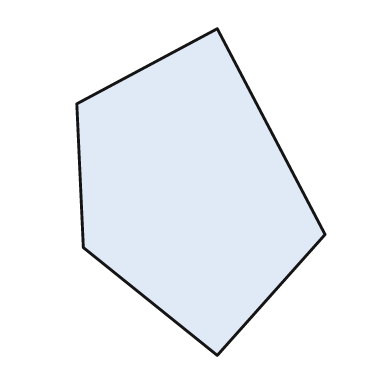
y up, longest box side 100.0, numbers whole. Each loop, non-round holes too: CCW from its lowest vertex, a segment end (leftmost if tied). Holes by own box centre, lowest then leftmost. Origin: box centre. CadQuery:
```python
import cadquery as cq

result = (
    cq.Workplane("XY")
    .moveTo(5.0, -50.0)
    .lineTo(38.0, -13.0)
    .lineTo(5.0, 50.0)
    .lineTo(-38.0, 27.0)
    .lineTo(-36.0, -17.0)
    .close()
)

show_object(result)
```